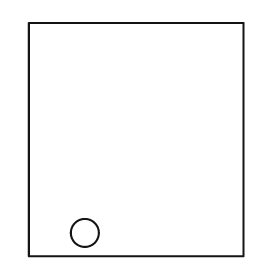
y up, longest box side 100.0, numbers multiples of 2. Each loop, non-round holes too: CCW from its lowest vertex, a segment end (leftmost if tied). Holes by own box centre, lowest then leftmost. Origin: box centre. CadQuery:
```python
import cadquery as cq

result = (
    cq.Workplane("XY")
    .moveTo(-46.0, -50.0)
    .lineTo(46.0, -50.0)
    .lineTo(46.0, 50.0)
    .lineTo(-46.0, 50.0)
    .close()
    .moveTo(-22.0, -40.0)
    .circle(6.0)
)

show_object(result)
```